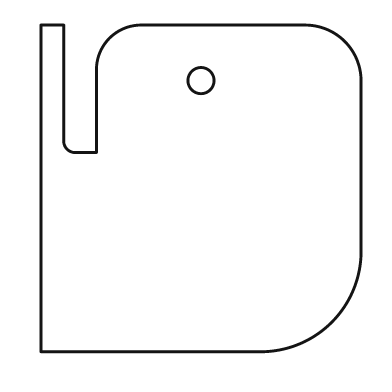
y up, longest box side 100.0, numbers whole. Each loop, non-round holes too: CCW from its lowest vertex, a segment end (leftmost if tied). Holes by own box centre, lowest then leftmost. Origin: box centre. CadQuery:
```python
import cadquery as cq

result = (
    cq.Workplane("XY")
    .moveTo(-49.0, -50.0)
    .lineTo(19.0, -50.0)
    .threePointArc((40.0, -41.0), (49.0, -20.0))
    .lineTo(49.0, 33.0)
    .threePointArc((44.0, 45.0), (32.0, 50.0))
    .lineTo(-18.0, 50.0)
    .threePointArc((-28.0, 46.0), (-32.0, 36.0))
    .lineTo(-32.0, 11.0)
    .lineTo(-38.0, 11.0)
    .threePointArc((-41.0, 12.0), (-42.0, 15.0))
    .lineTo(-42.0, 50.0)
    .lineTo(-49.0, 50.0)
    .close()
    .moveTo(0.0, 33.0)
    .circle(4.0)
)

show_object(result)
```